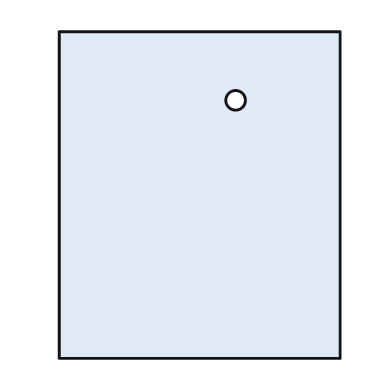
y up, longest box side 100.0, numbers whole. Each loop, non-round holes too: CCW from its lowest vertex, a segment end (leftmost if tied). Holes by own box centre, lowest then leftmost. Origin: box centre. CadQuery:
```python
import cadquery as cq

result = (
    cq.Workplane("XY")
    .moveTo(-43.0, -50.0)
    .lineTo(43.0, -50.0)
    .lineTo(43.0, 50.0)
    .lineTo(-43.0, 50.0)
    .close()
    .moveTo(11.0, 29.0)
    .circle(3.0)
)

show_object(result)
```